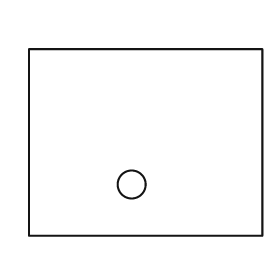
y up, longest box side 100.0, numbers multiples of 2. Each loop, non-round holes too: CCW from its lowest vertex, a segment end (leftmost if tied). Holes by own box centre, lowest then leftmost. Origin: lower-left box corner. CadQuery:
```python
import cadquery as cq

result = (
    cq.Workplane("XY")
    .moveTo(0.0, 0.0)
    .lineTo(100.0, 0.0)
    .lineTo(100.0, 80.0)
    .lineTo(0.0, 80.0)
    .close()
    .moveTo(44.0, 22.0)
    .circle(6.0)
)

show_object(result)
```